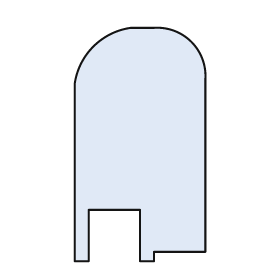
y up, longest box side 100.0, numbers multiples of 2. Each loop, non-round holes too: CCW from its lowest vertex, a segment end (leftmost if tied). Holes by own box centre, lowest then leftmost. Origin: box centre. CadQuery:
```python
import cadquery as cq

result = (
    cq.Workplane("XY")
    .moveTo(-28.0, -50.0)
    .lineTo(-22.0, -50.0)
    .lineTo(-22.0, -28.0)
    .lineTo(0.0, -28.0)
    .lineTo(0.0, -50.0)
    .lineTo(6.0, -50.0)
    .lineTo(6.0, -46.0)
    .lineTo(28.0, -46.0)
    .lineTo(28.0, 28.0)
    .threePointArc((22.0, 44.0), (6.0, 50.0))
    .lineTo(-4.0, 50.0)
    .threePointArc((-20.0, 42.0), (-28.0, 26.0))
    .close()
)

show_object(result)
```